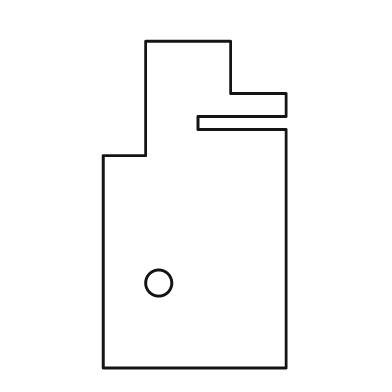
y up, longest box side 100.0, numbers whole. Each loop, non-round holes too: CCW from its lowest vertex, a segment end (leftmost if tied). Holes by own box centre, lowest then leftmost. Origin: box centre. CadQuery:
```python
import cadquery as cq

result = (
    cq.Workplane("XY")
    .moveTo(-28.0, -50.0)
    .lineTo(28.0, -50.0)
    .lineTo(28.0, 23.0)
    .lineTo(1.0, 23.0)
    .lineTo(1.0, 27.0)
    .lineTo(28.0, 27.0)
    .lineTo(28.0, 34.0)
    .lineTo(11.0, 34.0)
    .lineTo(11.0, 50.0)
    .lineTo(-15.0, 50.0)
    .lineTo(-15.0, 15.0)
    .lineTo(-28.0, 15.0)
    .close()
    .moveTo(-11.0, -24.0)
    .circle(4.0)
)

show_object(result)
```